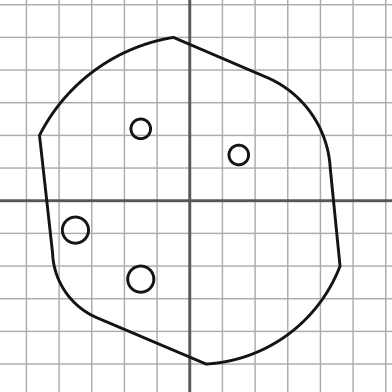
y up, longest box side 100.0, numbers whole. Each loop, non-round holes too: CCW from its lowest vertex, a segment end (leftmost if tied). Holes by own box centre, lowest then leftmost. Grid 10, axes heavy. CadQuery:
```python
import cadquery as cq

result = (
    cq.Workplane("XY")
    .moveTo(5.0, -50.0)
    .threePointArc((30.0, -41.0), (46.0, -20.0))
    .lineTo(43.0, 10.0)
    .threePointArc((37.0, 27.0), (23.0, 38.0))
    .lineTo(-5.0, 50.0)
    .threePointArc((-29.0, 40.0), (-46.0, 20.0))
    .lineTo(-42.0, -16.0)
    .threePointArc((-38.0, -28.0), (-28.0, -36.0))
    .close()
    .moveTo(-15.0, -24.0)
    .circle(4.0)
    .moveTo(-35.0, -9.0)
    .circle(4.0)
    .moveTo(15.0, 14.0)
    .circle(3.0)
    .moveTo(-15.0, 22.0)
    .circle(3.0)
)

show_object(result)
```